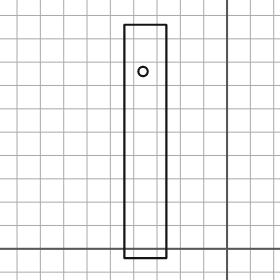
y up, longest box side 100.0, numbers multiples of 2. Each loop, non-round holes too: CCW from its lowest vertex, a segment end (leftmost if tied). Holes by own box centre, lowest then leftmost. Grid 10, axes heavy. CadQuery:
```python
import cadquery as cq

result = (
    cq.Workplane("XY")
    .moveTo(-44.0, -4.0)
    .lineTo(-26.0, -4.0)
    .lineTo(-26.0, 96.0)
    .lineTo(-44.0, 96.0)
    .close()
    .moveTo(-36.0, 76.0)
    .circle(2.0)
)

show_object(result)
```